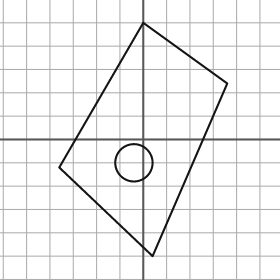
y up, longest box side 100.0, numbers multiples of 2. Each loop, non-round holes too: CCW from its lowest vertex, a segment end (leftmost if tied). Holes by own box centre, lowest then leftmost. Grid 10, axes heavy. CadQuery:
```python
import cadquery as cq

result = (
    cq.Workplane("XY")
    .moveTo(4.0, -50.0)
    .lineTo(36.0, 24.0)
    .lineTo(0.0, 50.0)
    .lineTo(-36.0, -12.0)
    .close()
    .moveTo(-4.0, -10.0)
    .circle(8.0)
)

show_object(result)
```